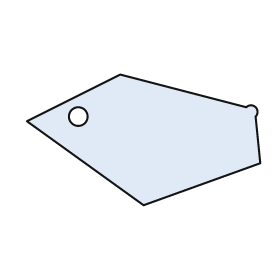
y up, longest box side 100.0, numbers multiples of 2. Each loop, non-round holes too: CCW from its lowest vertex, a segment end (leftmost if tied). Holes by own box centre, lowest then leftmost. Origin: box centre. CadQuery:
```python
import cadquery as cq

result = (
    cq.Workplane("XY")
    .moveTo(0.0, -28.0)
    .lineTo(50.0, -10.0)
    .lineTo(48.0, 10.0)
    .threePointArc((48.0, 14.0), (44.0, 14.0))
    .lineTo(-10.0, 28.0)
    .lineTo(-50.0, 8.0)
    .close()
    .moveTo(-28.0, 10.0)
    .circle(4.0)
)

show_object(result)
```